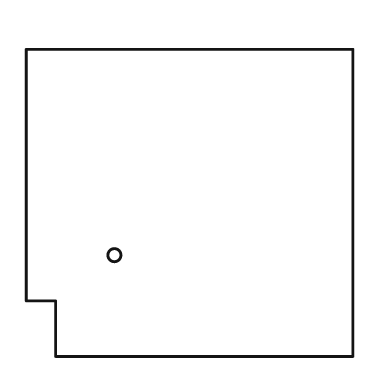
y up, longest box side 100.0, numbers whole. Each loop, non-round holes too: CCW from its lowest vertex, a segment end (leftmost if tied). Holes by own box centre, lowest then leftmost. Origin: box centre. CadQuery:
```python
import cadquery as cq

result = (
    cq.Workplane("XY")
    .moveTo(-41.0, -47.0)
    .lineTo(50.0, -47.0)
    .lineTo(50.0, 47.0)
    .lineTo(-50.0, 47.0)
    .lineTo(-50.0, -30.0)
    .lineTo(-41.0, -30.0)
    .close()
    .moveTo(-23.0, -16.0)
    .circle(2.0)
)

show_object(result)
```